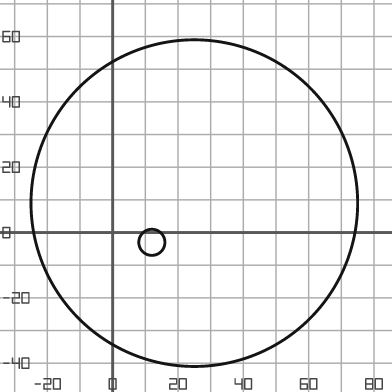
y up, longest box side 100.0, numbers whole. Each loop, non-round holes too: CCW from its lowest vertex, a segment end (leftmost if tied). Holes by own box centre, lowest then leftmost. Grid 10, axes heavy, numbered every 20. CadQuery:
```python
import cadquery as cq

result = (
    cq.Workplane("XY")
    .moveTo(25.0, 9.0)
    .circle(50.0)
    .moveTo(12.0, -3.0)
    .circle(4.0)
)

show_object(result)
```